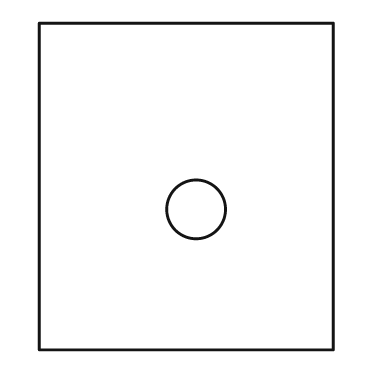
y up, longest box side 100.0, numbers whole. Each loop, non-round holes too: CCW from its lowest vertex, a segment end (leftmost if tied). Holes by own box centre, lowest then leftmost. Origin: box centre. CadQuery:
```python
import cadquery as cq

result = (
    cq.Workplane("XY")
    .moveTo(-45.0, -50.0)
    .lineTo(45.0, -50.0)
    .lineTo(45.0, 50.0)
    .lineTo(-45.0, 50.0)
    .close()
    .moveTo(3.0, -7.0)
    .circle(9.0)
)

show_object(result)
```